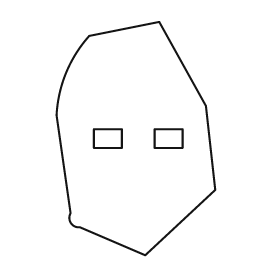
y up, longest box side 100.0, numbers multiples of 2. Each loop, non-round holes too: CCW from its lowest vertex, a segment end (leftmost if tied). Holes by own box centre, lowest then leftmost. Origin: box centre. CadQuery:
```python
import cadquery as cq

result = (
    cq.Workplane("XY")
    .moveTo(4.0, -50.0)
    .lineTo(34.0, -22.0)
    .lineTo(30.0, 14.0)
    .lineTo(10.0, 50.0)
    .lineTo(-20.0, 44.0)
    .threePointArc((-30.0, 28.0), (-34.0, 10.0))
    .lineTo(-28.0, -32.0)
    .threePointArc((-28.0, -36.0), (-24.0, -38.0))
    .close()
    .moveTo(-18.0, -4.0)
    .lineTo(-6.0, -4.0)
    .lineTo(-6.0, 4.0)
    .lineTo(-18.0, 4.0)
    .close()
    .moveTo(8.0, -4.0)
    .lineTo(20.0, -4.0)
    .lineTo(20.0, 4.0)
    .lineTo(8.0, 4.0)
    .close()
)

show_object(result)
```